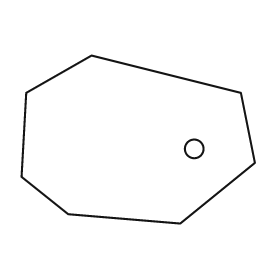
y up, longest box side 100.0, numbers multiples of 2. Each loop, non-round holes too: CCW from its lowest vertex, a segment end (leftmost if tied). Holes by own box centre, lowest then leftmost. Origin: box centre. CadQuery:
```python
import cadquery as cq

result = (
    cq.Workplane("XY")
    .moveTo(18.0, -36.0)
    .lineTo(50.0, -10.0)
    .lineTo(44.0, 20.0)
    .lineTo(-20.0, 36.0)
    .lineTo(-48.0, 20.0)
    .lineTo(-50.0, -16.0)
    .lineTo(-30.0, -32.0)
    .close()
    .moveTo(24.0, -4.0)
    .circle(4.0)
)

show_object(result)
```